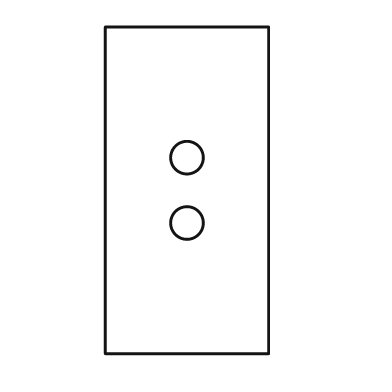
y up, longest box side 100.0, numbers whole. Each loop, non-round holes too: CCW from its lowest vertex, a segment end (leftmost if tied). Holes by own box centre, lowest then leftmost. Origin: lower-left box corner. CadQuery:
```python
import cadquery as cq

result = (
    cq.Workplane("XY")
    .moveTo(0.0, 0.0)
    .lineTo(50.0, 0.0)
    .lineTo(50.0, 100.0)
    .lineTo(0.0, 100.0)
    .close()
    .moveTo(25.0, 40.0)
    .circle(5.0)
    .moveTo(25.0, 60.0)
    .circle(5.0)
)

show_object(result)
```